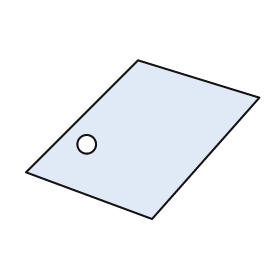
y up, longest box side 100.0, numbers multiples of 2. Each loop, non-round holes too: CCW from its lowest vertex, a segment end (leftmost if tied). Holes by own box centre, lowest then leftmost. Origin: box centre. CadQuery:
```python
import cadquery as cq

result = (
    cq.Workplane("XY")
    .moveTo(4.0, -34.0)
    .lineTo(50.0, 18.0)
    .lineTo(-2.0, 34.0)
    .lineTo(-50.0, -14.0)
    .close()
    .moveTo(-24.0, -2.0)
    .circle(4.0)
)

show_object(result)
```